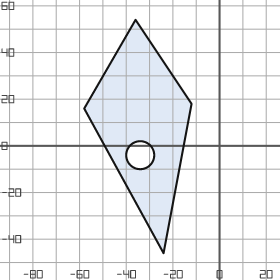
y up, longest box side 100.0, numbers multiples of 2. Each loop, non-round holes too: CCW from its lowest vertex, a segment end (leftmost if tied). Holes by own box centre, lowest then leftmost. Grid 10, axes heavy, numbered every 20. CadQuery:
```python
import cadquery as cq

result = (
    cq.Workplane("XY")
    .moveTo(-24.0, -46.0)
    .lineTo(-12.0, 18.0)
    .lineTo(-36.0, 54.0)
    .lineTo(-58.0, 16.0)
    .close()
    .moveTo(-34.0, -4.0)
    .circle(6.0)
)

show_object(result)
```